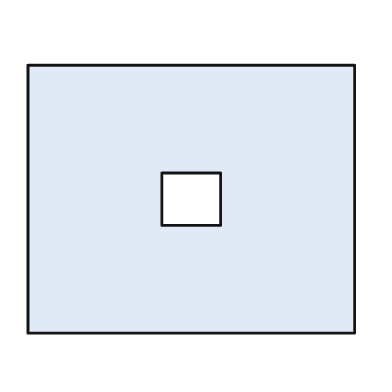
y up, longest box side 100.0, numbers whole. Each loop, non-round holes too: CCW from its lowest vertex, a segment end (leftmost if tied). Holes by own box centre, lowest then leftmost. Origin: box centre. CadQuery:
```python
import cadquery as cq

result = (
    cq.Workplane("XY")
    .moveTo(-50.0, -41.0)
    .lineTo(50.0, -41.0)
    .lineTo(50.0, 41.0)
    .lineTo(-50.0, 41.0)
    .close()
    .moveTo(-9.0, -8.0)
    .lineTo(9.0, -8.0)
    .lineTo(9.0, 8.0)
    .lineTo(-9.0, 8.0)
    .close()
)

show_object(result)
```